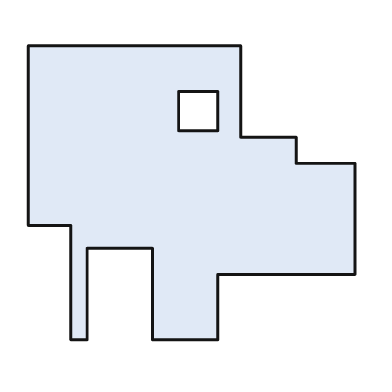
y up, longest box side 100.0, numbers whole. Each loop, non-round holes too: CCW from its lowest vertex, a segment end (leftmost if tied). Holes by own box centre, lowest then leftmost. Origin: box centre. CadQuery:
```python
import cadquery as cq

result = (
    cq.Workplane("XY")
    .moveTo(-37.0, -45.0)
    .lineTo(-32.0, -45.0)
    .lineTo(-32.0, -17.0)
    .lineTo(-12.0, -17.0)
    .lineTo(-12.0, -45.0)
    .lineTo(8.0, -45.0)
    .lineTo(8.0, -25.0)
    .lineTo(50.0, -25.0)
    .lineTo(50.0, 9.0)
    .lineTo(32.0, 9.0)
    .lineTo(32.0, 17.0)
    .lineTo(15.0, 17.0)
    .lineTo(15.0, 45.0)
    .lineTo(-50.0, 45.0)
    .lineTo(-50.0, -10.0)
    .lineTo(-37.0, -10.0)
    .close()
    .moveTo(-4.0, 19.0)
    .lineTo(8.0, 19.0)
    .lineTo(8.0, 31.0)
    .lineTo(-4.0, 31.0)
    .close()
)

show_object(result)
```